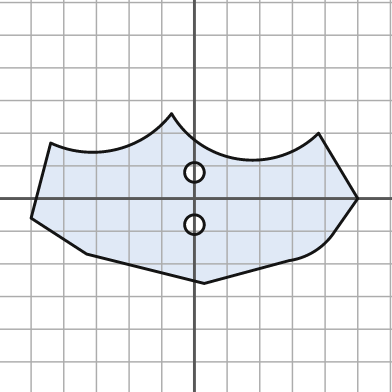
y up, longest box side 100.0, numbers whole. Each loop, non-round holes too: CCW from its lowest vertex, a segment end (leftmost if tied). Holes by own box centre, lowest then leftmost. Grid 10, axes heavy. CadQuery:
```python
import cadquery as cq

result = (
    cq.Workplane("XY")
    .moveTo(3.0, -26.0)
    .lineTo(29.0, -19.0)
    .threePointArc((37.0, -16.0), (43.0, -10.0))
    .lineTo(50.0, 0.0)
    .lineTo(38.0, 20.0)
    .threePointArc((14.0, 12.0), (-7.0, 26.0))
    .threePointArc((-24.0, 15.0), (-44.0, 17.0))
    .lineTo(-50.0, -6.0)
    .lineTo(-33.0, -17.0)
    .close()
    .moveTo(0.0, -8.0)
    .circle(3.0)
    .moveTo(0.0, 8.0)
    .circle(3.0)
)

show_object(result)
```